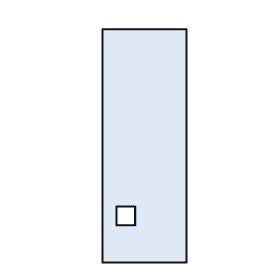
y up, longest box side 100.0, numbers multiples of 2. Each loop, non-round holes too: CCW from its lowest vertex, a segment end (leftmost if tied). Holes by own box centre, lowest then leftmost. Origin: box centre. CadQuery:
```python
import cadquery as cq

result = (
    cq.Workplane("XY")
    .moveTo(-18.0, -50.0)
    .lineTo(18.0, -50.0)
    .lineTo(18.0, 50.0)
    .lineTo(-18.0, 50.0)
    .close()
    .moveTo(-12.0, -34.0)
    .lineTo(-4.0, -34.0)
    .lineTo(-4.0, -26.0)
    .lineTo(-12.0, -26.0)
    .close()
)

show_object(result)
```